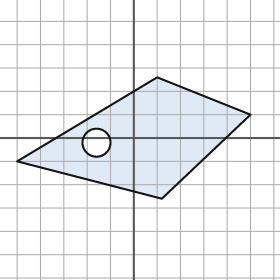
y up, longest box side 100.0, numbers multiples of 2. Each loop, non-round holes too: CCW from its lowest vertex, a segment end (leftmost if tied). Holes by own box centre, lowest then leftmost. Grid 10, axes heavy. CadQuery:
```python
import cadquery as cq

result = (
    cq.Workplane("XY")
    .moveTo(12.0, -26.0)
    .lineTo(50.0, 10.0)
    .lineTo(10.0, 26.0)
    .lineTo(-50.0, -10.0)
    .close()
    .moveTo(-16.0, -2.0)
    .circle(6.0)
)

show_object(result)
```